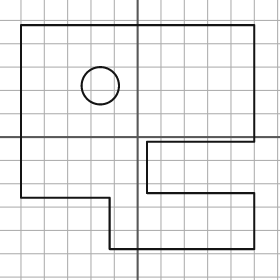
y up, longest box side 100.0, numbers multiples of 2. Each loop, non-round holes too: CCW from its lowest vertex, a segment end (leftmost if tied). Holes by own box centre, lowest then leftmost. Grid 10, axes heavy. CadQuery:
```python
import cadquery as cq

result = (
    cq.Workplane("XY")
    .moveTo(-12.0, -48.0)
    .lineTo(50.0, -48.0)
    .lineTo(50.0, -24.0)
    .lineTo(4.0, -24.0)
    .lineTo(4.0, -2.0)
    .lineTo(50.0, -2.0)
    .lineTo(50.0, 48.0)
    .lineTo(-50.0, 48.0)
    .lineTo(-50.0, -26.0)
    .lineTo(-12.0, -26.0)
    .close()
    .moveTo(-16.0, 22.0)
    .circle(8.0)
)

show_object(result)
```